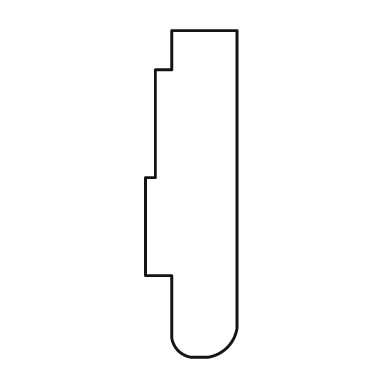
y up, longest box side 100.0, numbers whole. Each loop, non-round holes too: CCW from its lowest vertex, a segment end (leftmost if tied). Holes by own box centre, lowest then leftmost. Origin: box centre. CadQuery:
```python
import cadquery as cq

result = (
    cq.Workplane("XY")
    .moveTo(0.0, -50.0)
    .lineTo(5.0, -50.0)
    .threePointArc((11.0, -47.0), (14.0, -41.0))
    .lineTo(14.0, 50.0)
    .lineTo(-6.0, 50.0)
    .lineTo(-6.0, 38.0)
    .lineTo(-11.0, 38.0)
    .lineTo(-11.0, 5.0)
    .lineTo(-14.0, 5.0)
    .lineTo(-14.0, -25.0)
    .lineTo(-6.0, -25.0)
    .lineTo(-6.0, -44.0)
    .threePointArc((-4.0, -48.0), (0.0, -50.0))
    .close()
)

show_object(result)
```